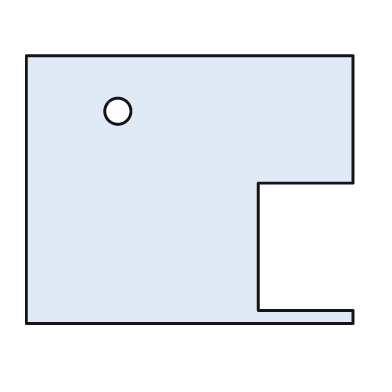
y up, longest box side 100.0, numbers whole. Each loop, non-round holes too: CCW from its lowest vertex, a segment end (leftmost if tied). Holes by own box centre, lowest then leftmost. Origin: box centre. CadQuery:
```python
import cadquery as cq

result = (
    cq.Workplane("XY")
    .moveTo(-50.0, -41.0)
    .lineTo(50.0, -41.0)
    .lineTo(50.0, -37.0)
    .lineTo(21.0, -37.0)
    .lineTo(21.0, 2.0)
    .lineTo(50.0, 2.0)
    .lineTo(50.0, 41.0)
    .lineTo(-50.0, 41.0)
    .close()
    .moveTo(-22.0, 24.0)
    .circle(4.0)
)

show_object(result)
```